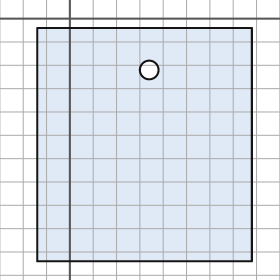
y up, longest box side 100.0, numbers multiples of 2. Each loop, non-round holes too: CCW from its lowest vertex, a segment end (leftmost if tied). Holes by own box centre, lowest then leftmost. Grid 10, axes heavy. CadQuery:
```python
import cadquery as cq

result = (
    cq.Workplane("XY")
    .moveTo(-14.0, -104.0)
    .lineTo(78.0, -104.0)
    .lineTo(78.0, -4.0)
    .lineTo(-14.0, -4.0)
    .close()
    .moveTo(34.0, -22.0)
    .circle(4.0)
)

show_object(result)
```